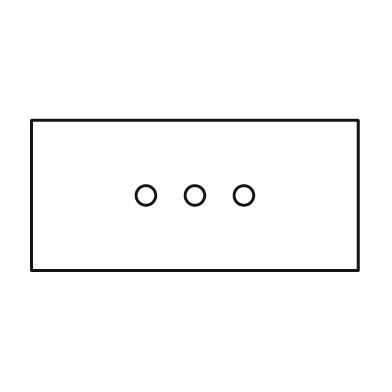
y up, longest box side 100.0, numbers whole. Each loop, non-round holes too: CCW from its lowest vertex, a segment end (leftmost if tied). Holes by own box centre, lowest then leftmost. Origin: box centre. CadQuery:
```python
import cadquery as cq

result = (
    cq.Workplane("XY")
    .moveTo(-50.0, -23.0)
    .lineTo(50.0, -23.0)
    .lineTo(50.0, 23.0)
    .lineTo(-50.0, 23.0)
    .close()
    .moveTo(-15.0, 0.0)
    .circle(3.0)
    .moveTo(0.0, 0.0)
    .circle(3.0)
    .moveTo(15.0, 0.0)
    .circle(3.0)
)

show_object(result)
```